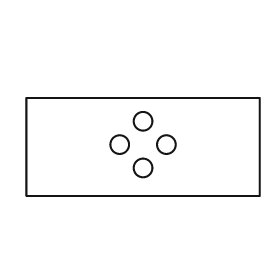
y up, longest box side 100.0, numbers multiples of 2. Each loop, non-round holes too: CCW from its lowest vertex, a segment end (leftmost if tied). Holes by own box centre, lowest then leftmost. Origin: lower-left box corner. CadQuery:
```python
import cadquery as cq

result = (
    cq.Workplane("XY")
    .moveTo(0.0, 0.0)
    .lineTo(100.0, 0.0)
    .lineTo(100.0, 42.0)
    .lineTo(0.0, 42.0)
    .close()
    .moveTo(50.0, 12.0)
    .circle(4.0)
    .moveTo(40.0, 22.0)
    .circle(4.0)
    .moveTo(60.0, 22.0)
    .circle(4.0)
    .moveTo(50.0, 32.0)
    .circle(4.0)
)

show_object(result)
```